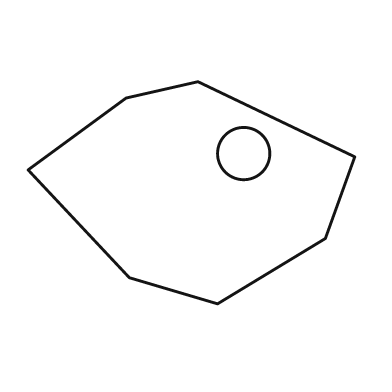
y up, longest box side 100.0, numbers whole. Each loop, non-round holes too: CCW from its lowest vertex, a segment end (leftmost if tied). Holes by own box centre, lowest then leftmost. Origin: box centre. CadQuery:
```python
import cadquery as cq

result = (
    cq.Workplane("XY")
    .moveTo(8.0, -34.0)
    .lineTo(41.0, -14.0)
    .lineTo(50.0, 11.0)
    .lineTo(2.0, 34.0)
    .lineTo(-20.0, 29.0)
    .lineTo(-50.0, 7.0)
    .lineTo(-19.0, -26.0)
    .close()
    .moveTo(16.0, 12.0)
    .circle(8.0)
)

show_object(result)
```